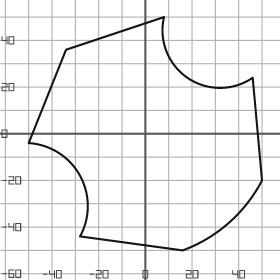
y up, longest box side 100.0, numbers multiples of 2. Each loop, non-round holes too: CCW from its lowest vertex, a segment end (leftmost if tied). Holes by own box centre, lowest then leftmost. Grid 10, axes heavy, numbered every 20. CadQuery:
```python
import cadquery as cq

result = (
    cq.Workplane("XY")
    .moveTo(16.0, -50.0)
    .threePointArc((36.0, -38.0), (50.0, -20.0))
    .lineTo(46.0, 24.0)
    .threePointArc((18.0, 24.0), (8.0, 50.0))
    .lineTo(-34.0, 36.0)
    .lineTo(-50.0, -4.0)
    .threePointArc((-28.0, -18.0), (-28.0, -44.0))
    .close()
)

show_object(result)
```